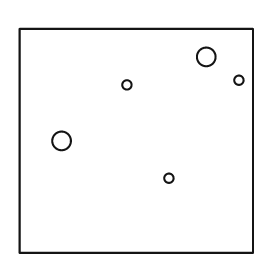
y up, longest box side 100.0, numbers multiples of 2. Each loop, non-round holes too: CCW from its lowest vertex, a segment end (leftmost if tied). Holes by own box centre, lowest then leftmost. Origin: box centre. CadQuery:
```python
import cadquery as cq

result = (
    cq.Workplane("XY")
    .moveTo(-50.0, -48.0)
    .lineTo(50.0, -48.0)
    .lineTo(50.0, 48.0)
    .lineTo(-50.0, 48.0)
    .close()
    .moveTo(14.0, -16.0)
    .circle(2.0)
    .moveTo(-32.0, 0.0)
    .circle(4.0)
    .moveTo(-4.0, 24.0)
    .circle(2.0)
    .moveTo(44.0, 26.0)
    .circle(2.0)
    .moveTo(30.0, 36.0)
    .circle(4.0)
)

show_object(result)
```